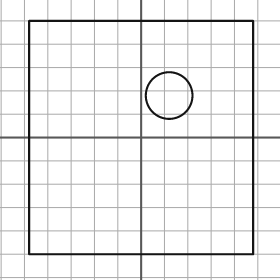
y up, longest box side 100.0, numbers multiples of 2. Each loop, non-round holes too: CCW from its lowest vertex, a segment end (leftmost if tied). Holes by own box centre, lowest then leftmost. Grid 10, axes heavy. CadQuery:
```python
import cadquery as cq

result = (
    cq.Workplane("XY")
    .moveTo(-48.0, -50.0)
    .lineTo(48.0, -50.0)
    .lineTo(48.0, 50.0)
    .lineTo(-48.0, 50.0)
    .close()
    .moveTo(12.0, 18.0)
    .circle(10.0)
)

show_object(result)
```